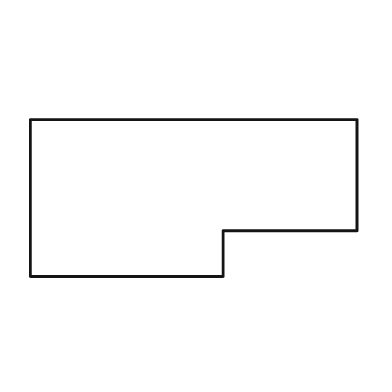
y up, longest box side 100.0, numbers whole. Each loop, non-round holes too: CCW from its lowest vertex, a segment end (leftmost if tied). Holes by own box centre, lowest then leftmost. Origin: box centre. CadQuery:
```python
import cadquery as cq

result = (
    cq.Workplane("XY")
    .moveTo(-50.0, -24.0)
    .lineTo(9.0, -24.0)
    .lineTo(9.0, -10.0)
    .lineTo(50.0, -10.0)
    .lineTo(50.0, 24.0)
    .lineTo(-50.0, 24.0)
    .close()
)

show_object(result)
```